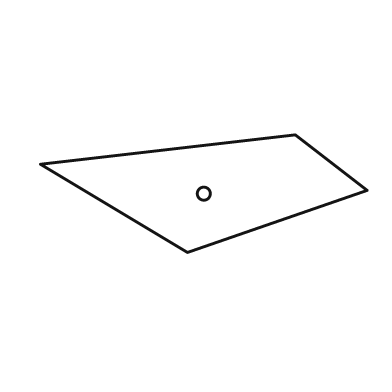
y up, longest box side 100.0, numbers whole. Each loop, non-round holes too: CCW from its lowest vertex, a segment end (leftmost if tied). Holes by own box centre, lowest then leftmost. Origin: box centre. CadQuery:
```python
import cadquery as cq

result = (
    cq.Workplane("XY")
    .moveTo(-5.0, -18.0)
    .lineTo(50.0, 1.0)
    .lineTo(28.0, 18.0)
    .lineTo(-50.0, 9.0)
    .close()
    .moveTo(0.0, 0.0)
    .circle(2.0)
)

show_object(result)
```